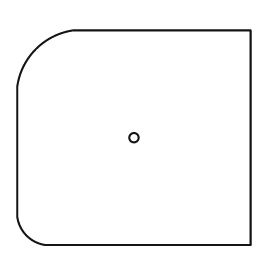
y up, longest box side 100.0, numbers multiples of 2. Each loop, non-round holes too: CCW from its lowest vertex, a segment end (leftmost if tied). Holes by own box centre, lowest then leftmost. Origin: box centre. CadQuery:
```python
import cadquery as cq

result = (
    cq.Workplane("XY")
    .moveTo(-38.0, -46.0)
    .lineTo(50.0, -46.0)
    .lineTo(50.0, 46.0)
    .lineTo(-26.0, 46.0)
    .threePointArc((-42.0, 38.0), (-50.0, 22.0))
    .lineTo(-50.0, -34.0)
    .threePointArc((-46.0, -42.0), (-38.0, -46.0))
    .close()
    .moveTo(0.0, 0.0)
    .circle(2.0)
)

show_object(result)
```